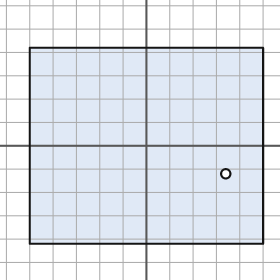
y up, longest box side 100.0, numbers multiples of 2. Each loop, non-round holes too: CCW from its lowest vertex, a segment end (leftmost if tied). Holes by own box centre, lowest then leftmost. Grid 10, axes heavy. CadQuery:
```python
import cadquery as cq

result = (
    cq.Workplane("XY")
    .moveTo(-50.0, -42.0)
    .lineTo(50.0, -42.0)
    .lineTo(50.0, 42.0)
    .lineTo(-50.0, 42.0)
    .close()
    .moveTo(34.0, -12.0)
    .circle(2.0)
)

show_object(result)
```